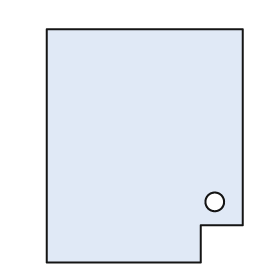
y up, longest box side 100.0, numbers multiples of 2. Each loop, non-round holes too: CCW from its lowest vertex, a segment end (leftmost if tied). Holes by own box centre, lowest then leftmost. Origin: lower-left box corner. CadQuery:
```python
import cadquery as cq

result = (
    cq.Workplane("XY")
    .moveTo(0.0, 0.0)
    .lineTo(66.0, 0.0)
    .lineTo(66.0, 16.0)
    .lineTo(84.0, 16.0)
    .lineTo(84.0, 100.0)
    .lineTo(0.0, 100.0)
    .close()
    .moveTo(72.0, 26.0)
    .circle(4.0)
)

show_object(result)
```